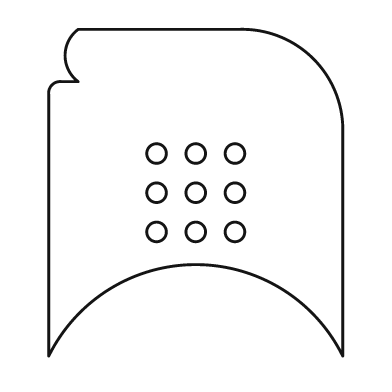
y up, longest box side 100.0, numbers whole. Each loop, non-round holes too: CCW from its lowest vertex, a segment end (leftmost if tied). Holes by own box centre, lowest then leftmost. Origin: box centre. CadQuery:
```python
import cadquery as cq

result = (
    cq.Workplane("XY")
    .moveTo(-45.0, -50.0)
    .threePointArc((0.0, -22.0), (45.0, -50.0))
    .lineTo(45.0, 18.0)
    .threePointArc((36.0, 41.0), (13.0, 50.0))
    .lineTo(-36.0, 50.0)
    .threePointArc((-40.0, 42.0), (-36.0, 34.0))
    .lineTo(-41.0, 34.0)
    .threePointArc((-44.0, 33.0), (-45.0, 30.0))
    .close()
    .moveTo(-12.0, -12.0)
    .circle(3.0)
    .moveTo(0.0, -12.0)
    .circle(3.0)
    .moveTo(12.0, -12.0)
    .circle(3.0)
    .moveTo(-12.0, 0.0)
    .circle(3.0)
    .moveTo(0.0, 0.0)
    .circle(3.0)
    .moveTo(12.0, 0.0)
    .circle(3.0)
    .moveTo(-12.0, 12.0)
    .circle(3.0)
    .moveTo(0.0, 12.0)
    .circle(3.0)
    .moveTo(12.0, 12.0)
    .circle(3.0)
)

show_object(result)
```